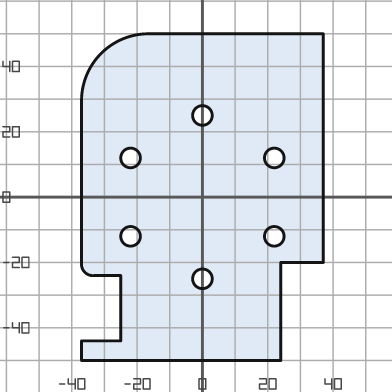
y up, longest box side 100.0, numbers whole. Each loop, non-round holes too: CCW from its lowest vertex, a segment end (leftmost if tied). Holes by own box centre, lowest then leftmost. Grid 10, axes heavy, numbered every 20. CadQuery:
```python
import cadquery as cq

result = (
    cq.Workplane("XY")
    .moveTo(-37.0, -50.0)
    .lineTo(24.0, -50.0)
    .lineTo(24.0, -20.0)
    .lineTo(37.0, -20.0)
    .lineTo(37.0, 50.0)
    .lineTo(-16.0, 50.0)
    .threePointArc((-31.0, 44.0), (-37.0, 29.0))
    .lineTo(-37.0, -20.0)
    .threePointArc((-36.0, -23.0), (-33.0, -24.0))
    .lineTo(-25.0, -24.0)
    .lineTo(-25.0, -44.0)
    .lineTo(-37.0, -44.0)
    .close()
    .moveTo(0.0, -25.0)
    .circle(3.0)
    .moveTo(-22.0, -12.0)
    .circle(3.0)
    .moveTo(22.0, -12.0)
    .circle(3.0)
    .moveTo(-22.0, 12.0)
    .circle(3.0)
    .moveTo(22.0, 12.0)
    .circle(3.0)
    .moveTo(0.0, 25.0)
    .circle(3.0)
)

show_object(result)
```